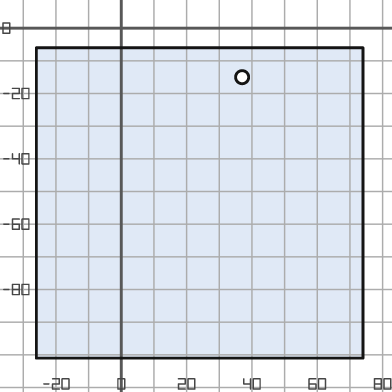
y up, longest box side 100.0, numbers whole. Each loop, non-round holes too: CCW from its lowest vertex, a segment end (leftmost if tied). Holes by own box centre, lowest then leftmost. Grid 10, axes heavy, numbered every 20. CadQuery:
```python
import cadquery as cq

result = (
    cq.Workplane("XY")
    .moveTo(-26.0, -101.0)
    .lineTo(74.0, -101.0)
    .lineTo(74.0, -6.0)
    .lineTo(-26.0, -6.0)
    .close()
    .moveTo(37.0, -15.0)
    .circle(2.0)
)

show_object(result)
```